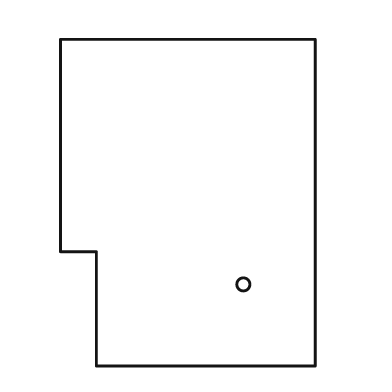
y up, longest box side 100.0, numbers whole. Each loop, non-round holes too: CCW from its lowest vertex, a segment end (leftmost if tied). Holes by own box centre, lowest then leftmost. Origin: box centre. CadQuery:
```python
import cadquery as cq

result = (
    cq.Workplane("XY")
    .moveTo(-28.0, -50.0)
    .lineTo(39.0, -50.0)
    .lineTo(39.0, 50.0)
    .lineTo(-39.0, 50.0)
    .lineTo(-39.0, -15.0)
    .lineTo(-28.0, -15.0)
    .close()
    .moveTo(17.0, -25.0)
    .circle(2.0)
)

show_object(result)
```